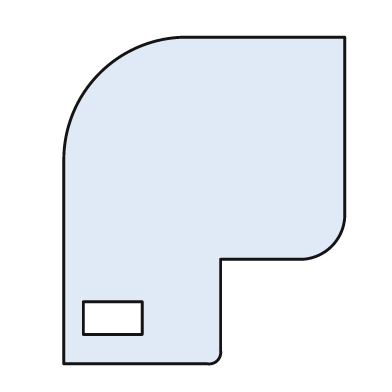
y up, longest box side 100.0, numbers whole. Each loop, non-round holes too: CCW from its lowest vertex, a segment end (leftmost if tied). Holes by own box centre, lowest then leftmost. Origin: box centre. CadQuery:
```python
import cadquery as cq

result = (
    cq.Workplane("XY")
    .moveTo(-43.0, -50.0)
    .lineTo(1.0, -50.0)
    .threePointArc((4.0, -49.0), (5.0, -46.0))
    .lineTo(5.0, -18.0)
    .lineTo(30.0, -18.0)
    .threePointArc((39.0, -14.0), (43.0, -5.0))
    .lineTo(43.0, 50.0)
    .lineTo(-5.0, 50.0)
    .threePointArc((-32.0, 39.0), (-43.0, 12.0))
    .close()
    .moveTo(-37.0, -41.0)
    .lineTo(-19.0, -41.0)
    .lineTo(-19.0, -31.0)
    .lineTo(-37.0, -31.0)
    .close()
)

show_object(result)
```